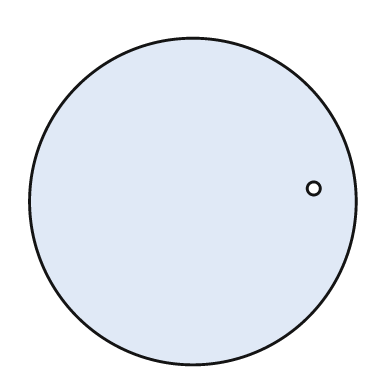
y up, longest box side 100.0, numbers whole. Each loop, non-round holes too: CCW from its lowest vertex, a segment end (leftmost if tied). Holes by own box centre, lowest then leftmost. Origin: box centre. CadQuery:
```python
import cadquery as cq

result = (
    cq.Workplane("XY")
    .moveTo(0.0, 0.0)
    .circle(50.0)
    .moveTo(37.0, 4.0)
    .circle(2.0)
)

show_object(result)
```